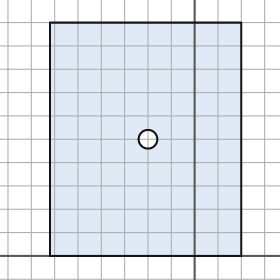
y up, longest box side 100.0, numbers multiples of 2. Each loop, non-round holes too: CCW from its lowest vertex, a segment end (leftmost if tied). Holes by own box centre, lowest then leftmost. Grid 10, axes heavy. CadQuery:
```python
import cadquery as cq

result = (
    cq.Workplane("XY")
    .moveTo(-62.0, 0.0)
    .lineTo(20.0, 0.0)
    .lineTo(20.0, 100.0)
    .lineTo(-62.0, 100.0)
    .close()
    .moveTo(-20.0, 50.0)
    .circle(4.0)
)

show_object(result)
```